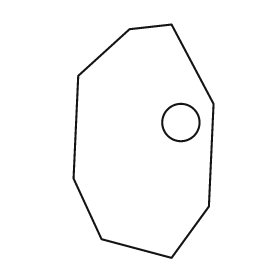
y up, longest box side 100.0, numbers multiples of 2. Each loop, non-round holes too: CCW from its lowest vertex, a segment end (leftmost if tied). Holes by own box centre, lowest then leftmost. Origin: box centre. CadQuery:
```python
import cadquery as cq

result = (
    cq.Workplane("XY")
    .moveTo(12.0, -50.0)
    .lineTo(28.0, -28.0)
    .lineTo(30.0, 16.0)
    .lineTo(12.0, 50.0)
    .lineTo(-6.0, 48.0)
    .lineTo(-28.0, 28.0)
    .lineTo(-30.0, -16.0)
    .lineTo(-18.0, -42.0)
    .close()
    .moveTo(16.0, 8.0)
    .circle(8.0)
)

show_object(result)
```